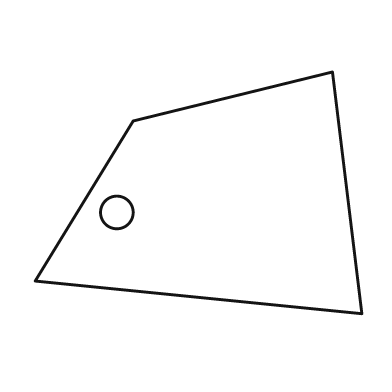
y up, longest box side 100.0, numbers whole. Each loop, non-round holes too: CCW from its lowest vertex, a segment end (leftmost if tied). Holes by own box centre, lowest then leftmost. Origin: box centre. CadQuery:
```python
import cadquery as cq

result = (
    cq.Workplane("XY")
    .moveTo(50.0, -37.0)
    .lineTo(41.0, 37.0)
    .lineTo(-20.0, 22.0)
    .lineTo(-50.0, -27.0)
    .close()
    .moveTo(-25.0, -6.0)
    .circle(5.0)
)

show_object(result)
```